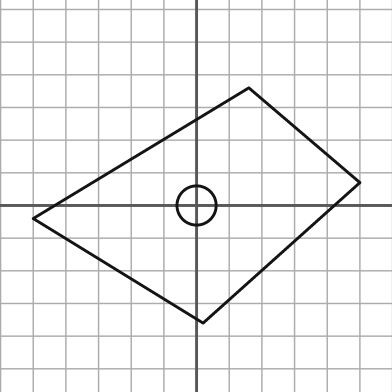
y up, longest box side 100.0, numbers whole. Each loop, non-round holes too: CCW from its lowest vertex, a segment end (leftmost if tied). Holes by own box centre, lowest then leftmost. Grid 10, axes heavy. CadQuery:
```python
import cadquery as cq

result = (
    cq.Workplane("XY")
    .moveTo(2.0, -36.0)
    .lineTo(50.0, 7.0)
    .lineTo(16.0, 36.0)
    .lineTo(-50.0, -4.0)
    .close()
    .moveTo(0.0, 0.0)
    .circle(6.0)
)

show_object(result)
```